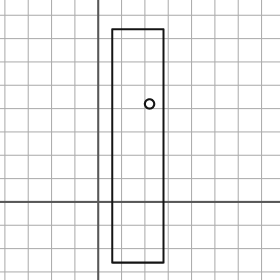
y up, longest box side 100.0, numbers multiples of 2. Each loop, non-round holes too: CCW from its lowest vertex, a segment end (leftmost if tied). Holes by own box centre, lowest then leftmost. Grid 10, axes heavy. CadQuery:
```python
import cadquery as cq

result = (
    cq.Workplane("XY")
    .moveTo(6.0, -26.0)
    .lineTo(28.0, -26.0)
    .lineTo(28.0, 74.0)
    .lineTo(6.0, 74.0)
    .close()
    .moveTo(22.0, 42.0)
    .circle(2.0)
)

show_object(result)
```